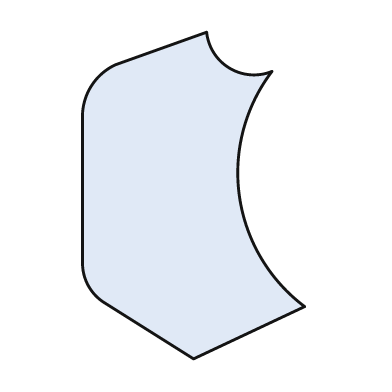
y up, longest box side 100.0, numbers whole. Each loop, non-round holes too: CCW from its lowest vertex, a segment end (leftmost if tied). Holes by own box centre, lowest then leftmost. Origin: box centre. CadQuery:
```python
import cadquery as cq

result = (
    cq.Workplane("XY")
    .moveTo(0.0, -50.0)
    .lineTo(34.0, -34.0)
    .threePointArc((14.0, 0.0), (24.0, 38.0))
    .threePointArc((11.0, 39.0), (4.0, 50.0))
    .lineTo(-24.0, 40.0)
    .threePointArc((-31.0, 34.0), (-34.0, 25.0))
    .lineTo(-34.0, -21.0)
    .threePointArc((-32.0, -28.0), (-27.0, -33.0))
    .close()
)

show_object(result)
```